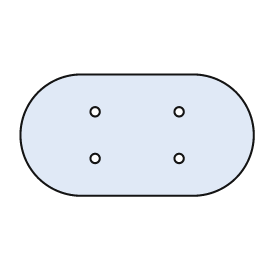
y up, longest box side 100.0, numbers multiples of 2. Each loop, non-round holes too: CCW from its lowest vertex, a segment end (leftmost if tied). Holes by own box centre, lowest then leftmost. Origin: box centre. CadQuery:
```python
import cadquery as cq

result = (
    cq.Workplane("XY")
    .moveTo(-24.0, -26.0)
    .lineTo(24.0, -26.0)
    .threePointArc((50.0, 0.0), (24.0, 26.0))
    .lineTo(-24.0, 26.0)
    .threePointArc((-50.0, 0.0), (-24.0, -26.0))
    .close()
    .moveTo(-18.0, -10.0)
    .circle(2.0)
    .moveTo(18.0, -10.0)
    .circle(2.0)
    .moveTo(-18.0, 10.0)
    .circle(2.0)
    .moveTo(18.0, 10.0)
    .circle(2.0)
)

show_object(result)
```